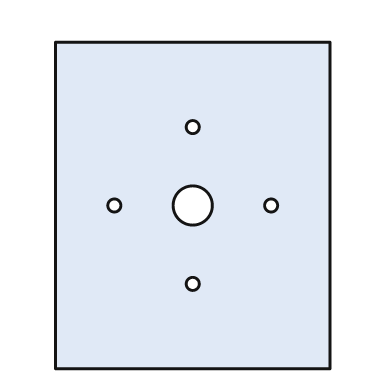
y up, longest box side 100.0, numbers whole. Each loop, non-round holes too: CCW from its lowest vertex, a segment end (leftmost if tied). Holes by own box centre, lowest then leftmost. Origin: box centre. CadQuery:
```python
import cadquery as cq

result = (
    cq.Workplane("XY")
    .moveTo(-42.0, -50.0)
    .lineTo(42.0, -50.0)
    .lineTo(42.0, 50.0)
    .lineTo(-42.0, 50.0)
    .close()
    .moveTo(0.0, -24.0)
    .circle(2.0)
    .moveTo(-24.0, 0.0)
    .circle(2.0)
    .moveTo(0.0, 0.0)
    .circle(6.0)
    .moveTo(24.0, 0.0)
    .circle(2.0)
    .moveTo(0.0, 24.0)
    .circle(2.0)
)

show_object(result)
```